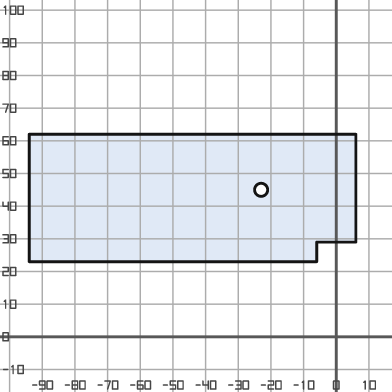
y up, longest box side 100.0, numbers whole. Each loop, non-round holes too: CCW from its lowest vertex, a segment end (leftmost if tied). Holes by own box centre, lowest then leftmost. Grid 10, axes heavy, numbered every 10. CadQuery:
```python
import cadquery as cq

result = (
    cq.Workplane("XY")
    .moveTo(-94.0, 23.0)
    .lineTo(-6.0, 23.0)
    .lineTo(-6.0, 29.0)
    .lineTo(6.0, 29.0)
    .lineTo(6.0, 62.0)
    .lineTo(-94.0, 62.0)
    .close()
    .moveTo(-23.0, 45.0)
    .circle(2.0)
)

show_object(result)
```